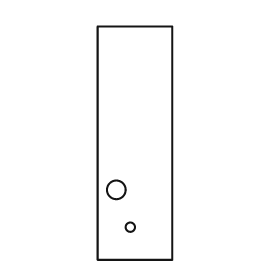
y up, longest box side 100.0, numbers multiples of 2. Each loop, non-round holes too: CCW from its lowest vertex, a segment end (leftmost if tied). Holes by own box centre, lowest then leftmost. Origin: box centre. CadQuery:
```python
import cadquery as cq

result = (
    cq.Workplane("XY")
    .moveTo(-16.0, -50.0)
    .lineTo(16.0, -50.0)
    .lineTo(16.0, 50.0)
    .lineTo(-16.0, 50.0)
    .close()
    .moveTo(-2.0, -36.0)
    .circle(2.0)
    .moveTo(-8.0, -20.0)
    .circle(4.0)
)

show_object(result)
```